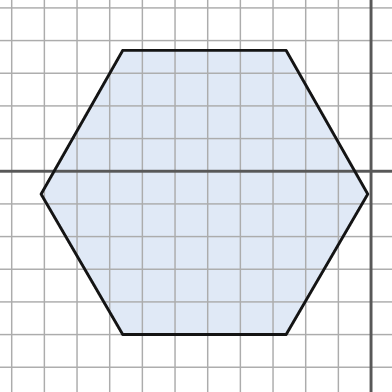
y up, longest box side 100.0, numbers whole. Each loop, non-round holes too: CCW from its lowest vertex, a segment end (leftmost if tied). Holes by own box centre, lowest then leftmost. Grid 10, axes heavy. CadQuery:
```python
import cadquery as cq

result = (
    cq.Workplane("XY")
    .moveTo(-76.0, -50.0)
    .lineTo(-26.0, -50.0)
    .lineTo(-1.0, -7.0)
    .lineTo(-26.0, 37.0)
    .lineTo(-76.0, 37.0)
    .lineTo(-101.0, -7.0)
    .close()
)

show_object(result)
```